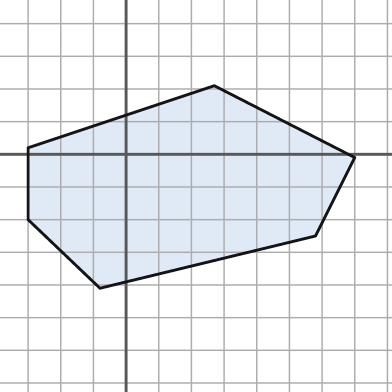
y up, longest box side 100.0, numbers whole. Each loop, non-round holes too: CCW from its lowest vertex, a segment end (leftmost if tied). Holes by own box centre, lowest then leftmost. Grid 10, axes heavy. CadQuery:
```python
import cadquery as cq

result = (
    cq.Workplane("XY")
    .moveTo(-8.0, -41.0)
    .lineTo(58.0, -25.0)
    .lineTo(70.0, -1.0)
    .lineTo(27.0, 21.0)
    .lineTo(-30.0, 2.0)
    .lineTo(-30.0, -20.0)
    .close()
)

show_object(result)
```